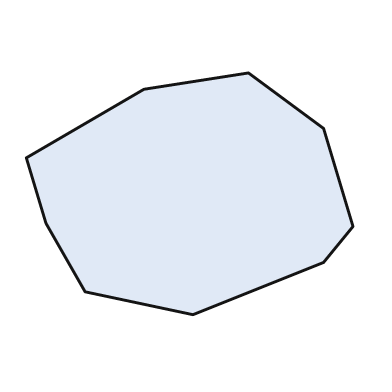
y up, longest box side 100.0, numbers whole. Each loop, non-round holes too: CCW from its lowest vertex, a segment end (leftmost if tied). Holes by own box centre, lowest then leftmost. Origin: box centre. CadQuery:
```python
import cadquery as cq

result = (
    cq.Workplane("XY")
    .moveTo(1.0, -37.0)
    .lineTo(41.0, -21.0)
    .lineTo(50.0, -10.0)
    .lineTo(41.0, 20.0)
    .lineTo(18.0, 37.0)
    .lineTo(-14.0, 32.0)
    .lineTo(-50.0, 11.0)
    .lineTo(-44.0, -9.0)
    .lineTo(-32.0, -30.0)
    .close()
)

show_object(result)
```